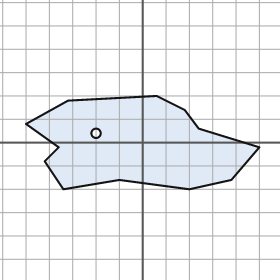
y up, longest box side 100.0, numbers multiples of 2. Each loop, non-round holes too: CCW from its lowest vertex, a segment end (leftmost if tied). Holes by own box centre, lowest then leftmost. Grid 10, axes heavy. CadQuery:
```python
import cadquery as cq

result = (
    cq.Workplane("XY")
    .moveTo(-34.0, -20.0)
    .lineTo(-10.0, -16.0)
    .lineTo(20.0, -20.0)
    .lineTo(38.0, -16.0)
    .lineTo(50.0, -2.0)
    .lineTo(24.0, 6.0)
    .lineTo(18.0, 14.0)
    .lineTo(6.0, 20.0)
    .lineTo(-32.0, 18.0)
    .lineTo(-50.0, 8.0)
    .lineTo(-36.0, -2.0)
    .lineTo(-42.0, -8.0)
    .close()
    .moveTo(-20.0, 4.0)
    .circle(2.0)
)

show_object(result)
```